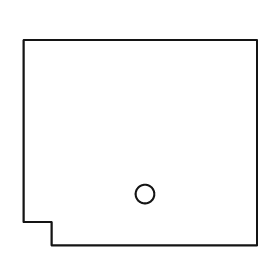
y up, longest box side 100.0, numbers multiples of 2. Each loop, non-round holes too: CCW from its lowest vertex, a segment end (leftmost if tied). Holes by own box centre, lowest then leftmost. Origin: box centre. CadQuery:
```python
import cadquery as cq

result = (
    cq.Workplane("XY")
    .moveTo(-38.0, -44.0)
    .lineTo(50.0, -44.0)
    .lineTo(50.0, 44.0)
    .lineTo(-50.0, 44.0)
    .lineTo(-50.0, -34.0)
    .lineTo(-38.0, -34.0)
    .close()
    .moveTo(2.0, -22.0)
    .circle(4.0)
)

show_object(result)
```